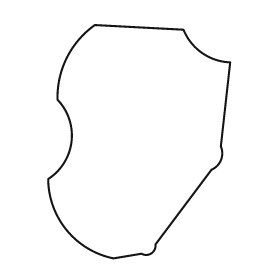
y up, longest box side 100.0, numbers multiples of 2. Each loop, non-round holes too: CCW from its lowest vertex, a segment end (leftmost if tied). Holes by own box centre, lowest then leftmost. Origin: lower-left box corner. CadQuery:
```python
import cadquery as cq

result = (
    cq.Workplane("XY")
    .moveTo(28.0, 0.0)
    .lineTo(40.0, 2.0)
    .threePointArc((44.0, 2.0), (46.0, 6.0))
    .lineTo(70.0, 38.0)
    .threePointArc((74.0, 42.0), (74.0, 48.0))
    .lineTo(78.0, 84.0)
    .threePointArc((66.0, 88.0), (58.0, 98.0))
    .lineTo(20.0, 100.0)
    .threePointArc((8.0, 86.0), (4.0, 68.0))
    .threePointArc((10.0, 50.0), (0.0, 34.0))
    .threePointArc((8.0, 12.0), (28.0, 0.0))
    .close()
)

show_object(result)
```